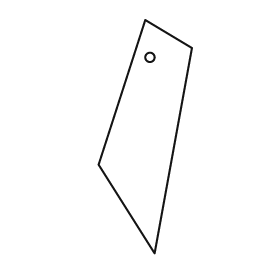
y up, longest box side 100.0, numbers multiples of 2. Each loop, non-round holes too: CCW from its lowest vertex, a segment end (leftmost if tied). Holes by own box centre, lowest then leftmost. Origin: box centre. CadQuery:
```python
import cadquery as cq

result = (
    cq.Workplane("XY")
    .moveTo(4.0, -50.0)
    .lineTo(20.0, 38.0)
    .lineTo(0.0, 50.0)
    .lineTo(-20.0, -12.0)
    .close()
    .moveTo(2.0, 34.0)
    .circle(2.0)
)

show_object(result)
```